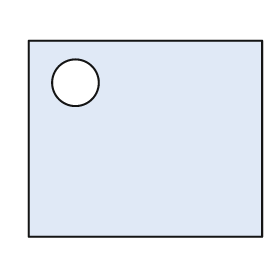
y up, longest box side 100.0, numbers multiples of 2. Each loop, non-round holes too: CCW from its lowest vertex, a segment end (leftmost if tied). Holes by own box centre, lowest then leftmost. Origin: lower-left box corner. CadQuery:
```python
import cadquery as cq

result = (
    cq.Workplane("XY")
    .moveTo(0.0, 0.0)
    .lineTo(100.0, 0.0)
    .lineTo(100.0, 84.0)
    .lineTo(0.0, 84.0)
    .close()
    .moveTo(20.0, 66.0)
    .circle(10.0)
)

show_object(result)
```